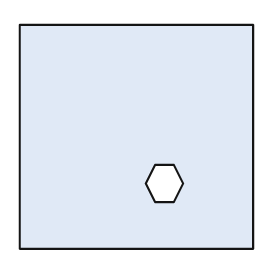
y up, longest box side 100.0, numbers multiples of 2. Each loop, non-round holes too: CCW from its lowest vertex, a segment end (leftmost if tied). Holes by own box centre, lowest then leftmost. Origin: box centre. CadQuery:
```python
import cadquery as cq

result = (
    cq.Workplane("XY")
    .moveTo(-50.0, -48.0)
    .lineTo(50.0, -48.0)
    .lineTo(50.0, 48.0)
    .lineTo(-50.0, 48.0)
    .close()
    .moveTo(8.0, -28.0)
    .lineTo(16.0, -28.0)
    .lineTo(20.0, -20.0)
    .lineTo(16.0, -12.0)
    .lineTo(8.0, -12.0)
    .lineTo(4.0, -20.0)
    .close()
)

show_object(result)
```